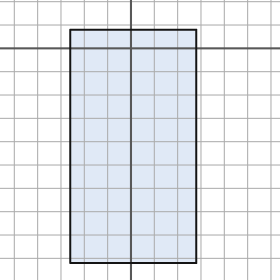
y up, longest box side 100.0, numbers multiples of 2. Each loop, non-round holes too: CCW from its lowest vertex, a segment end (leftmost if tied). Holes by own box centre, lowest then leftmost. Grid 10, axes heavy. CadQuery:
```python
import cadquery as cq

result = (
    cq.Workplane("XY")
    .moveTo(-26.0, -92.0)
    .lineTo(28.0, -92.0)
    .lineTo(28.0, 8.0)
    .lineTo(-26.0, 8.0)
    .close()
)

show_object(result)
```